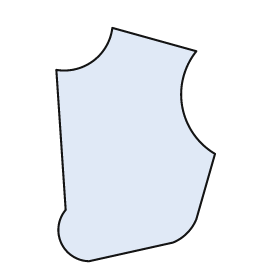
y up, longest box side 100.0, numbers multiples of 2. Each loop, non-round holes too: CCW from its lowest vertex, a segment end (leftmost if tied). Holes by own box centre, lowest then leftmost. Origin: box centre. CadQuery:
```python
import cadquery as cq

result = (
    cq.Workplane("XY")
    .moveTo(-20.0, -50.0)
    .lineTo(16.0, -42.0)
    .threePointArc((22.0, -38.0), (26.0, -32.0))
    .lineTo(34.0, -4.0)
    .threePointArc((20.0, 16.0), (26.0, 40.0))
    .lineTo(-10.0, 50.0)
    .threePointArc((-18.0, 36.0), (-34.0, 32.0))
    .lineTo(-30.0, -28.0)
    .threePointArc((-32.0, -42.0), (-20.0, -50.0))
    .close()
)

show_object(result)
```